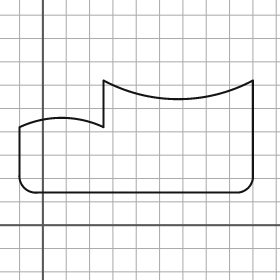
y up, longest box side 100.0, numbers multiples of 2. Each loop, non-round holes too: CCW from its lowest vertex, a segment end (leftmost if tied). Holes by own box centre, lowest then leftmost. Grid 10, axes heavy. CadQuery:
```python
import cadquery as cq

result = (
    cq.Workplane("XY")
    .moveTo(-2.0, 14.0)
    .lineTo(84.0, 14.0)
    .threePointArc((88.0, 16.0), (90.0, 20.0))
    .lineTo(90.0, 62.0)
    .threePointArc((58.0, 54.0), (26.0, 62.0))
    .lineTo(26.0, 42.0)
    .threePointArc((8.0, 46.0), (-10.0, 42.0))
    .lineTo(-10.0, 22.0)
    .threePointArc((-8.0, 16.0), (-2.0, 14.0))
    .close()
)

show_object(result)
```